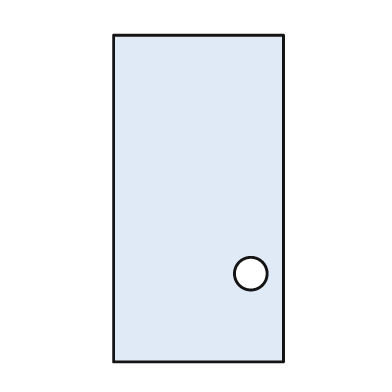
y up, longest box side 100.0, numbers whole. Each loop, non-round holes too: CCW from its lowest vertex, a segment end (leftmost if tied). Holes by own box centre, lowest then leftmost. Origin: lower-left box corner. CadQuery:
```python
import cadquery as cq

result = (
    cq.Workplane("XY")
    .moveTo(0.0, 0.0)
    .lineTo(52.0, 0.0)
    .lineTo(52.0, 100.0)
    .lineTo(0.0, 100.0)
    .close()
    .moveTo(42.0, 27.0)
    .circle(5.0)
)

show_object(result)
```